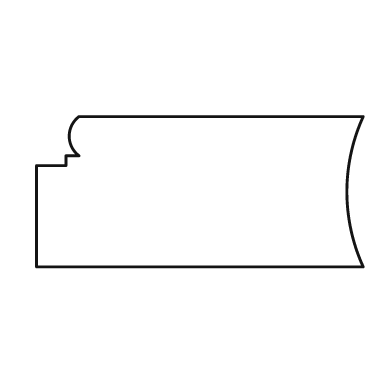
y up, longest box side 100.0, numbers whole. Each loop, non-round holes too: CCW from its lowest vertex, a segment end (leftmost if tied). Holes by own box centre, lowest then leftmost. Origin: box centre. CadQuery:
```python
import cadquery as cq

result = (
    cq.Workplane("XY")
    .moveTo(-50.0, -23.0)
    .lineTo(50.0, -23.0)
    .threePointArc((45.0, 0.0), (50.0, 23.0))
    .lineTo(-37.0, 23.0)
    .threePointArc((-40.0, 17.0), (-37.0, 11.0))
    .lineTo(-41.0, 11.0)
    .lineTo(-41.0, 8.0)
    .lineTo(-50.0, 8.0)
    .close()
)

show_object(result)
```